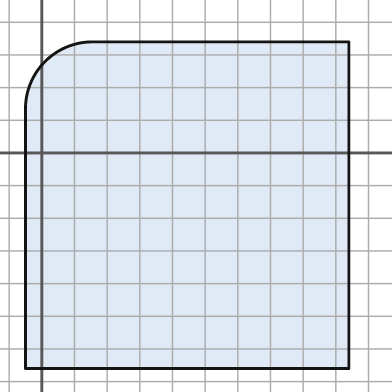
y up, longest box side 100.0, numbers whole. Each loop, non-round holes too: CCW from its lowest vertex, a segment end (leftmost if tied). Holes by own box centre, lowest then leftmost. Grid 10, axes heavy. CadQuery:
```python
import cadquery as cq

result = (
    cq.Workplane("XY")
    .moveTo(-5.0, -66.0)
    .lineTo(94.0, -66.0)
    .lineTo(94.0, 34.0)
    .lineTo(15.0, 34.0)
    .threePointArc((1.0, 28.0), (-5.0, 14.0))
    .close()
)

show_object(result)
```